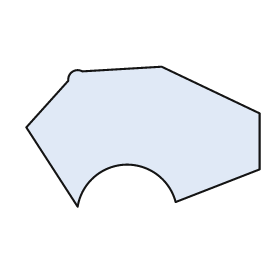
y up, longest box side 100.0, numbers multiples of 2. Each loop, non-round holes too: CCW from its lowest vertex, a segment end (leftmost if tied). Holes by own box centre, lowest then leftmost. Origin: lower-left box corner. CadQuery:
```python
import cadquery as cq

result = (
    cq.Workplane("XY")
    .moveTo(22.0, 0.0)
    .threePointArc((42.0, 18.0), (64.0, 2.0))
    .lineTo(100.0, 16.0)
    .lineTo(100.0, 40.0)
    .lineTo(58.0, 60.0)
    .lineTo(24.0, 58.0)
    .threePointArc((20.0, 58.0), (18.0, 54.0))
    .lineTo(0.0, 34.0)
    .close()
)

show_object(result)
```